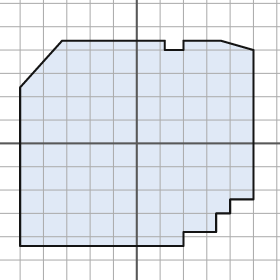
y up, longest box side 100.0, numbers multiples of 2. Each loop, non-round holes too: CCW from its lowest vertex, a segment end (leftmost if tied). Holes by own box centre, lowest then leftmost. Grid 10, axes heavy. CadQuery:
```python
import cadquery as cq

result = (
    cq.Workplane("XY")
    .moveTo(-50.0, -44.0)
    .lineTo(20.0, -44.0)
    .lineTo(20.0, -38.0)
    .lineTo(34.0, -38.0)
    .lineTo(34.0, -30.0)
    .lineTo(40.0, -30.0)
    .lineTo(40.0, -24.0)
    .lineTo(50.0, -24.0)
    .lineTo(50.0, 40.0)
    .lineTo(36.0, 44.0)
    .lineTo(20.0, 44.0)
    .lineTo(20.0, 40.0)
    .lineTo(12.0, 40.0)
    .lineTo(12.0, 44.0)
    .lineTo(-32.0, 44.0)
    .lineTo(-50.0, 24.0)
    .close()
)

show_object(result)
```